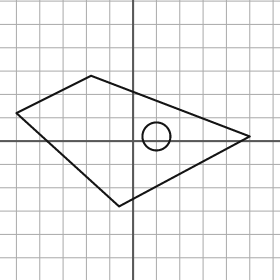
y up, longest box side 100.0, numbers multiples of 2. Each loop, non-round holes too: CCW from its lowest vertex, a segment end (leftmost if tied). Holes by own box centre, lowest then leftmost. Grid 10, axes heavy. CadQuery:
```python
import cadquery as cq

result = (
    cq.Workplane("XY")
    .moveTo(-6.0, -28.0)
    .lineTo(50.0, 2.0)
    .lineTo(-18.0, 28.0)
    .lineTo(-50.0, 12.0)
    .close()
    .moveTo(10.0, 2.0)
    .circle(6.0)
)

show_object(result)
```